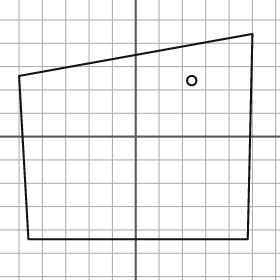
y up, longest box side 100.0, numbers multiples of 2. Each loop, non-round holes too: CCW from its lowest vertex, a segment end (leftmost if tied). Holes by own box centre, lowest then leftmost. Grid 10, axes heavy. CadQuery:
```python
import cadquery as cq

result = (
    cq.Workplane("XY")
    .moveTo(-46.0, -44.0)
    .lineTo(48.0, -44.0)
    .lineTo(50.0, 44.0)
    .lineTo(-50.0, 26.0)
    .close()
    .moveTo(24.0, 24.0)
    .circle(2.0)
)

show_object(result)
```